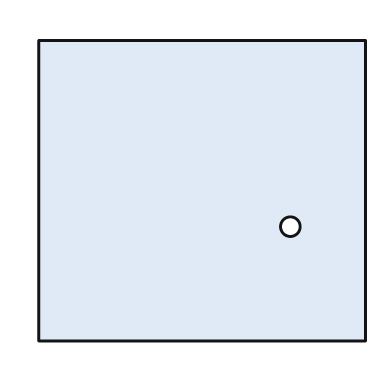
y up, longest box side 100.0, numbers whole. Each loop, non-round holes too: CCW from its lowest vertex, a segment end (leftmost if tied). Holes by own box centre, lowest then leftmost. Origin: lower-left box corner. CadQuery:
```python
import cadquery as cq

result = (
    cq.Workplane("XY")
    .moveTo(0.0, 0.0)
    .lineTo(100.0, 0.0)
    .lineTo(100.0, 92.0)
    .lineTo(0.0, 92.0)
    .close()
    .moveTo(77.0, 35.0)
    .circle(3.0)
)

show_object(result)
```